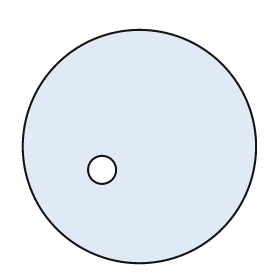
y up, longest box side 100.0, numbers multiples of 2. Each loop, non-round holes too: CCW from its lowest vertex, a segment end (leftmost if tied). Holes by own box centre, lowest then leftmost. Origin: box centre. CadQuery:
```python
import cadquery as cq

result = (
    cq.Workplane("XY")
    .moveTo(0.0, 0.0)
    .circle(50.0)
    .moveTo(-16.0, -10.0)
    .circle(6.0)
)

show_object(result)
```